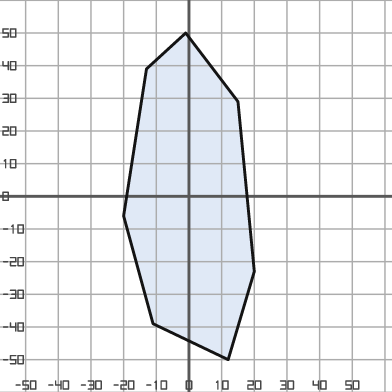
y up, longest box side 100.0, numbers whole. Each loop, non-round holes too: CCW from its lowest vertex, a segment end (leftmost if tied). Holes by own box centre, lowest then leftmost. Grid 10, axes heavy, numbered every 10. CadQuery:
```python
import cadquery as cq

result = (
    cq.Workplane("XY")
    .moveTo(12.0, -50.0)
    .lineTo(20.0, -23.0)
    .lineTo(15.0, 29.0)
    .lineTo(-1.0, 50.0)
    .lineTo(-13.0, 39.0)
    .lineTo(-20.0, -6.0)
    .lineTo(-11.0, -39.0)
    .close()
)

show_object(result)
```